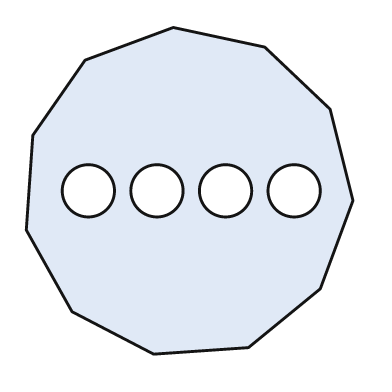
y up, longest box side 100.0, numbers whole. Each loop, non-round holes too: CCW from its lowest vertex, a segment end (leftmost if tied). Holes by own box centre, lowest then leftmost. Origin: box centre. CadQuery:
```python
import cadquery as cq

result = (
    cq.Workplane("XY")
    .moveTo(-11.0, -50.0)
    .lineTo(18.0, -48.0)
    .lineTo(40.0, -30.0)
    .lineTo(50.0, -3.0)
    .lineTo(43.0, 25.0)
    .lineTo(23.0, 44.0)
    .lineTo(-5.0, 50.0)
    .lineTo(-32.0, 40.0)
    .lineTo(-48.0, 17.0)
    .lineTo(-50.0, -12.0)
    .lineTo(-36.0, -37.0)
    .close()
    .moveTo(-31.0, 0.0)
    .circle(8.0)
    .moveTo(-10.0, 0.0)
    .circle(8.0)
    .moveTo(11.0, 0.0)
    .circle(8.0)
    .moveTo(32.0, 0.0)
    .circle(8.0)
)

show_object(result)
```